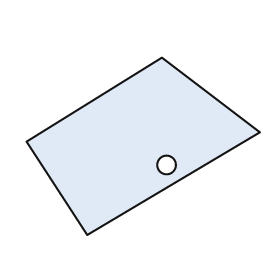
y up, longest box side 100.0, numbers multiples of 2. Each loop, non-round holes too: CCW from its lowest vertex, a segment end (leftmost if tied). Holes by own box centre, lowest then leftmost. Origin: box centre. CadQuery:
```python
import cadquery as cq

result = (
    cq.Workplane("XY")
    .moveTo(-24.0, -38.0)
    .lineTo(50.0, 6.0)
    .lineTo(8.0, 38.0)
    .lineTo(-50.0, 2.0)
    .close()
    .moveTo(10.0, -8.0)
    .circle(4.0)
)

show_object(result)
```